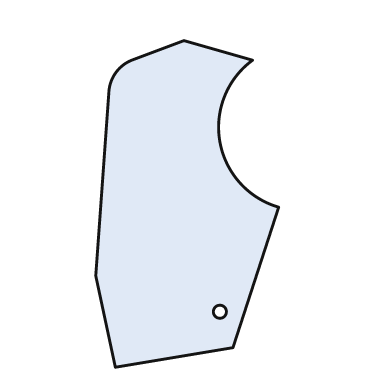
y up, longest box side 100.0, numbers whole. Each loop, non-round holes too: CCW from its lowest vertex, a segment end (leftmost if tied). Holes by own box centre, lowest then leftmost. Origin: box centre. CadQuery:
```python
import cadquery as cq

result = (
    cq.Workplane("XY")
    .moveTo(-22.0, -50.0)
    .lineTo(14.0, -44.0)
    .lineTo(28.0, -1.0)
    .threePointArc((10.0, 19.0), (20.0, 44.0))
    .lineTo(-1.0, 50.0)
    .lineTo(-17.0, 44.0)
    .threePointArc((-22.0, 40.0), (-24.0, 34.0))
    .lineTo(-28.0, -22.0)
    .close()
    .moveTo(10.0, -33.0)
    .circle(2.0)
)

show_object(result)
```